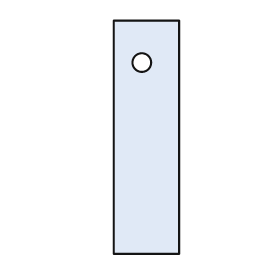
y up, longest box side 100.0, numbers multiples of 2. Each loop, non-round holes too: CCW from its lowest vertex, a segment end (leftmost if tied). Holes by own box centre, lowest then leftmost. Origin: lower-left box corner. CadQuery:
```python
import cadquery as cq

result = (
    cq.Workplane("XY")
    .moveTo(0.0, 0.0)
    .lineTo(28.0, 0.0)
    .lineTo(28.0, 100.0)
    .lineTo(0.0, 100.0)
    .close()
    .moveTo(12.0, 82.0)
    .circle(4.0)
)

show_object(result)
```